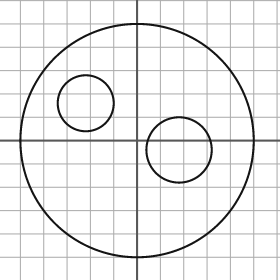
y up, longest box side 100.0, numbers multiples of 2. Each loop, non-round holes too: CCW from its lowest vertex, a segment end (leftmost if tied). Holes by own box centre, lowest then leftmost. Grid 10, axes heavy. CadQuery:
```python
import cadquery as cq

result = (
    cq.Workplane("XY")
    .moveTo(0.0, 0.0)
    .circle(50.0)
    .moveTo(18.0, -4.0)
    .circle(14.0)
    .moveTo(-22.0, 16.0)
    .circle(12.0)
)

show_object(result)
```